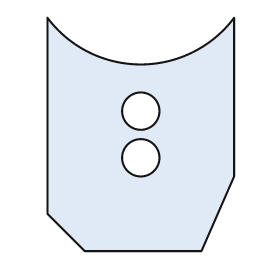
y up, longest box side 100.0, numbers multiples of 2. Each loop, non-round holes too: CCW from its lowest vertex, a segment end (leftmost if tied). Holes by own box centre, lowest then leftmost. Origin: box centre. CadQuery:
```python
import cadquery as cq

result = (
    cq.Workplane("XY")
    .moveTo(-24.0, -50.0)
    .lineTo(26.0, -50.0)
    .lineTo(40.0, -18.0)
    .lineTo(40.0, 50.0)
    .threePointArc((0.0, 30.0), (-40.0, 50.0))
    .lineTo(-40.0, -34.0)
    .close()
    .moveTo(0.0, -10.0)
    .circle(8.0)
    .moveTo(0.0, 10.0)
    .circle(8.0)
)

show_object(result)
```